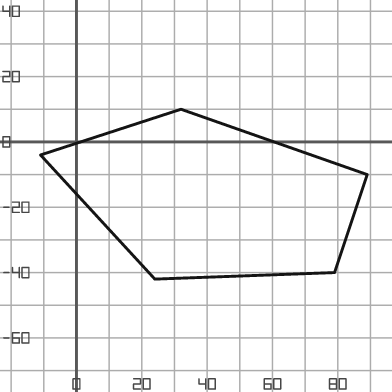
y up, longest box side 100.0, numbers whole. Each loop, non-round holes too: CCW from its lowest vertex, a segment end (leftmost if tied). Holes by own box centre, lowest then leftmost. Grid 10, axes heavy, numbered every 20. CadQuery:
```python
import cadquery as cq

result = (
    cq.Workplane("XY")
    .moveTo(24.0, -42.0)
    .lineTo(79.0, -40.0)
    .lineTo(89.0, -10.0)
    .lineTo(32.0, 10.0)
    .lineTo(-11.0, -4.0)
    .close()
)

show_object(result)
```